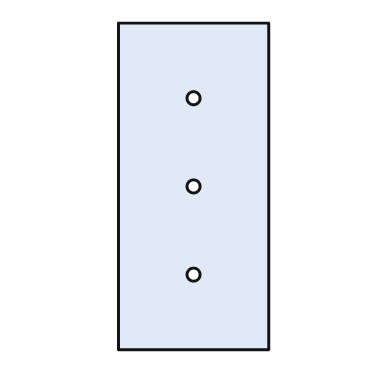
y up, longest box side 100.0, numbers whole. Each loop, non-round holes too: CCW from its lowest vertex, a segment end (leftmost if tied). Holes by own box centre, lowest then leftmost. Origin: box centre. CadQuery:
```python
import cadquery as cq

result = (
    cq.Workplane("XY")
    .moveTo(-23.0, -50.0)
    .lineTo(23.0, -50.0)
    .lineTo(23.0, 50.0)
    .lineTo(-23.0, 50.0)
    .close()
    .moveTo(0.0, -27.0)
    .circle(2.0)
    .moveTo(0.0, 0.0)
    .circle(2.0)
    .moveTo(0.0, 27.0)
    .circle(2.0)
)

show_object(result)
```